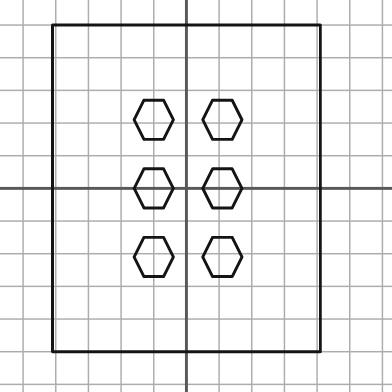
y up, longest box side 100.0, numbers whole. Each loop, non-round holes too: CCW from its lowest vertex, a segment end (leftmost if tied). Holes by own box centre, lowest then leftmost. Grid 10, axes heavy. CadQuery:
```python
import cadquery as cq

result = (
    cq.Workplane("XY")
    .moveTo(-41.0, -50.0)
    .lineTo(41.0, -50.0)
    .lineTo(41.0, 50.0)
    .lineTo(-41.0, 50.0)
    .close()
    .moveTo(-13.0, -27.0)
    .lineTo(-7.0, -27.0)
    .lineTo(-4.0, -21.0)
    .lineTo(-7.0, -15.0)
    .lineTo(-13.0, -15.0)
    .lineTo(-16.0, -21.0)
    .close()
    .moveTo(8.0, -27.0)
    .lineTo(14.0, -27.0)
    .lineTo(17.0, -21.0)
    .lineTo(14.0, -15.0)
    .lineTo(8.0, -15.0)
    .lineTo(5.0, -21.0)
    .close()
    .moveTo(-13.0, -6.0)
    .lineTo(-7.0, -6.0)
    .lineTo(-4.0, 0.0)
    .lineTo(-7.0, 6.0)
    .lineTo(-13.0, 6.0)
    .lineTo(-16.0, 0.0)
    .close()
    .moveTo(8.0, -6.0)
    .lineTo(14.0, -6.0)
    .lineTo(17.0, 0.0)
    .lineTo(14.0, 6.0)
    .lineTo(8.0, 6.0)
    .lineTo(5.0, 0.0)
    .close()
    .moveTo(-13.0, 15.0)
    .lineTo(-7.0, 15.0)
    .lineTo(-4.0, 21.0)
    .lineTo(-7.0, 27.0)
    .lineTo(-13.0, 27.0)
    .lineTo(-16.0, 21.0)
    .close()
    .moveTo(8.0, 15.0)
    .lineTo(14.0, 15.0)
    .lineTo(17.0, 21.0)
    .lineTo(14.0, 27.0)
    .lineTo(8.0, 27.0)
    .lineTo(5.0, 21.0)
    .close()
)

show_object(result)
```